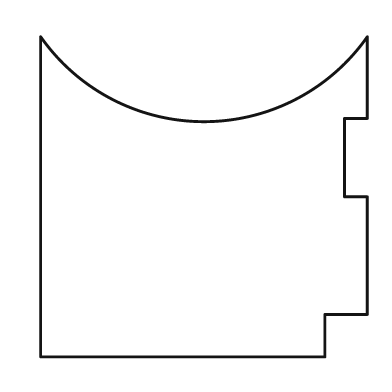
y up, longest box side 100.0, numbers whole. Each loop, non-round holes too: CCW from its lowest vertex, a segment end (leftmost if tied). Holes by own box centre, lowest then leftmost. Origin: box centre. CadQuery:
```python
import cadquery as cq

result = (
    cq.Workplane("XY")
    .moveTo(-50.0, -49.0)
    .lineTo(37.0, -49.0)
    .lineTo(37.0, -36.0)
    .lineTo(50.0, -36.0)
    .lineTo(50.0, 0.0)
    .lineTo(43.0, 0.0)
    .lineTo(43.0, 24.0)
    .lineTo(50.0, 24.0)
    .lineTo(50.0, 49.0)
    .threePointArc((0.0, 23.0), (-50.0, 49.0))
    .close()
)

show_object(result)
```